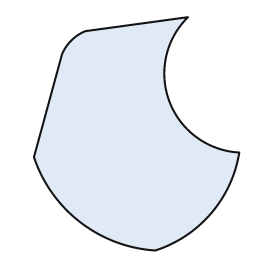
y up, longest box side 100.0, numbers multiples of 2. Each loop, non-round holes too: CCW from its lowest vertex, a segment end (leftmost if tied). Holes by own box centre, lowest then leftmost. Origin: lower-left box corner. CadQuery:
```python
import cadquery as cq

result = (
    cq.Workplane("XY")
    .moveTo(52.0, 0.0)
    .threePointArc((76.0, 16.0), (88.0, 42.0))
    .threePointArc((58.0, 64.0), (66.0, 100.0))
    .lineTo(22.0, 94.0)
    .threePointArc((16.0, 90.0), (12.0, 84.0))
    .lineTo(0.0, 40.0)
    .threePointArc((20.0, 12.0), (52.0, 0.0))
    .close()
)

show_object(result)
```